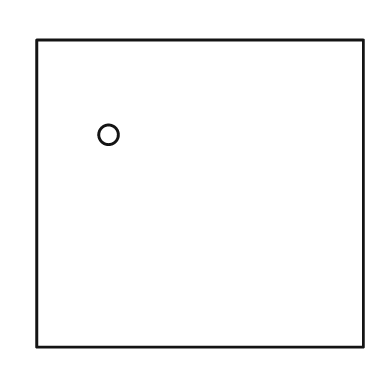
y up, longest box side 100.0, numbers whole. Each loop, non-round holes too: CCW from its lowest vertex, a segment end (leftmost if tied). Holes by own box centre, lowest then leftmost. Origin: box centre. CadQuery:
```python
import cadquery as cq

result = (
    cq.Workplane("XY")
    .moveTo(-50.0, -47.0)
    .lineTo(50.0, -47.0)
    .lineTo(50.0, 47.0)
    .lineTo(-50.0, 47.0)
    .close()
    .moveTo(-28.0, 18.0)
    .circle(3.0)
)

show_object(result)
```